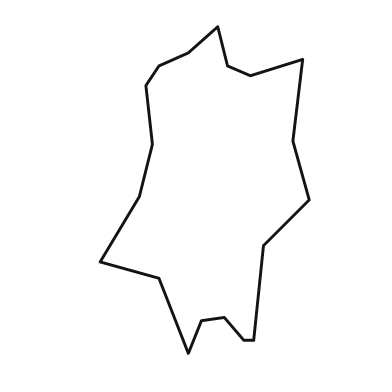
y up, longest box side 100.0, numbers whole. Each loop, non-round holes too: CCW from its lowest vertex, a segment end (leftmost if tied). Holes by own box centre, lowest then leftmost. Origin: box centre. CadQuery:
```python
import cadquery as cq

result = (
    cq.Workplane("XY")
    .moveTo(-5.0, -50.0)
    .lineTo(-1.0, -40.0)
    .lineTo(6.0, -39.0)
    .lineTo(12.0, -46.0)
    .lineTo(15.0, -46.0)
    .lineTo(18.0, -17.0)
    .lineTo(32.0, -3.0)
    .lineTo(27.0, 15.0)
    .lineTo(30.0, 40.0)
    .lineTo(14.0, 35.0)
    .lineTo(7.0, 38.0)
    .lineTo(4.0, 50.0)
    .lineTo(-5.0, 42.0)
    .lineTo(-14.0, 38.0)
    .lineTo(-18.0, 32.0)
    .lineTo(-16.0, 14.0)
    .lineTo(-20.0, -2.0)
    .lineTo(-32.0, -22.0)
    .lineTo(-14.0, -27.0)
    .close()
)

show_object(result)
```